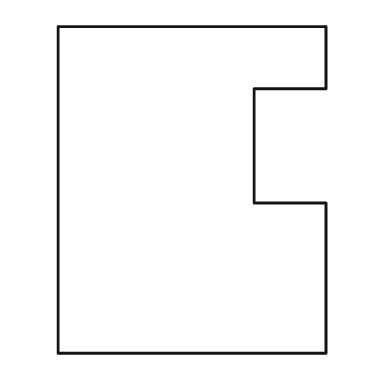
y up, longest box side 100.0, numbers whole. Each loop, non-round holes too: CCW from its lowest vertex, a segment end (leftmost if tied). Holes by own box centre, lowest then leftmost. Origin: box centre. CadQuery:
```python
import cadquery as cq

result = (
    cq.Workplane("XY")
    .moveTo(-41.0, -50.0)
    .lineTo(41.0, -50.0)
    .lineTo(41.0, -4.0)
    .lineTo(19.0, -4.0)
    .lineTo(19.0, 31.0)
    .lineTo(41.0, 31.0)
    .lineTo(41.0, 50.0)
    .lineTo(-41.0, 50.0)
    .close()
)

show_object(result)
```